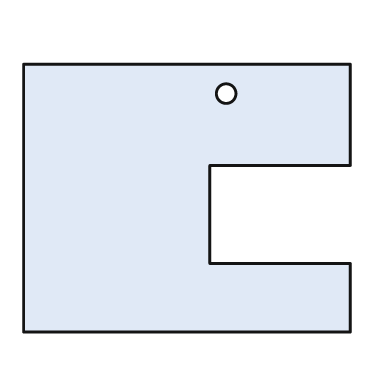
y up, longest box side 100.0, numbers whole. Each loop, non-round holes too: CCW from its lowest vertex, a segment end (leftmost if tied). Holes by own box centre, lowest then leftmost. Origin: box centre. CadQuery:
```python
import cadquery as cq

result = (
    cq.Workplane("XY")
    .moveTo(-50.0, -41.0)
    .lineTo(50.0, -41.0)
    .lineTo(50.0, -20.0)
    .lineTo(7.0, -20.0)
    .lineTo(7.0, 10.0)
    .lineTo(50.0, 10.0)
    .lineTo(50.0, 41.0)
    .lineTo(-50.0, 41.0)
    .close()
    .moveTo(12.0, 32.0)
    .circle(3.0)
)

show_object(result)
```